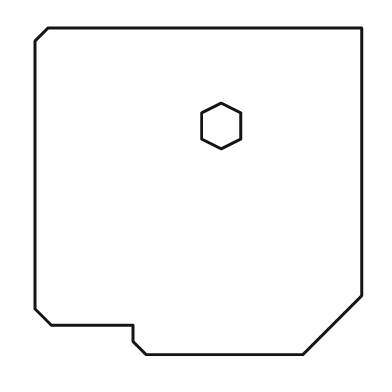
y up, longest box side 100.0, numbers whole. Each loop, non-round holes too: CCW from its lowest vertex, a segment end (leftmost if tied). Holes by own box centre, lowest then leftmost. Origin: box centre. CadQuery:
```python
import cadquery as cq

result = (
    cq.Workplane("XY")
    .moveTo(-16.0, -50.0)
    .lineTo(32.0, -50.0)
    .lineTo(50.0, -32.0)
    .lineTo(50.0, 50.0)
    .lineTo(-46.0, 50.0)
    .lineTo(-50.0, 46.0)
    .lineTo(-50.0, -36.0)
    .lineTo(-45.0, -41.0)
    .lineTo(-20.0, -41.0)
    .lineTo(-20.0, -46.0)
    .close()
    .moveTo(7.0, 13.0)
    .lineTo(13.0, 16.0)
    .lineTo(13.0, 24.0)
    .lineTo(7.0, 27.0)
    .lineTo(1.0, 24.0)
    .lineTo(1.0, 16.0)
    .close()
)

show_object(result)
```